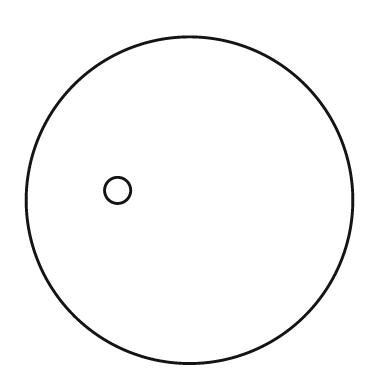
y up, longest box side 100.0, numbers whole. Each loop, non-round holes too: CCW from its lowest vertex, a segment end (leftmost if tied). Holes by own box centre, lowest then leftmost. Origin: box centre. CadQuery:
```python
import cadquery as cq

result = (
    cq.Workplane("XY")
    .moveTo(0.0, 0.0)
    .circle(50.0)
    .moveTo(-22.0, 3.0)
    .circle(4.0)
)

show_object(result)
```